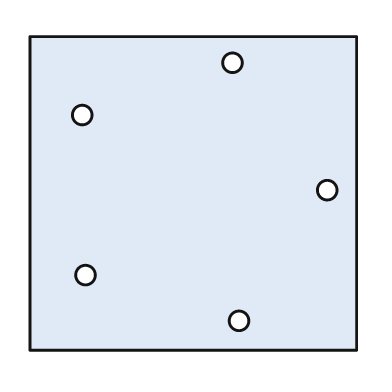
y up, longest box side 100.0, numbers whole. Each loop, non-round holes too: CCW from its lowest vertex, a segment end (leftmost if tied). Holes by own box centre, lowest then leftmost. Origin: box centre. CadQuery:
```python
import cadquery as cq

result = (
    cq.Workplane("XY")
    .moveTo(-50.0, -48.0)
    .lineTo(50.0, -48.0)
    .lineTo(50.0, 48.0)
    .lineTo(-50.0, 48.0)
    .close()
    .moveTo(14.0, -39.0)
    .circle(3.0)
    .moveTo(-33.0, -25.0)
    .circle(3.0)
    .moveTo(41.0, 1.0)
    .circle(3.0)
    .moveTo(-34.0, 24.0)
    .circle(3.0)
    .moveTo(12.0, 40.0)
    .circle(3.0)
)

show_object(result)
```